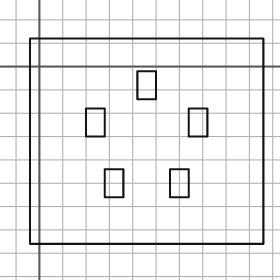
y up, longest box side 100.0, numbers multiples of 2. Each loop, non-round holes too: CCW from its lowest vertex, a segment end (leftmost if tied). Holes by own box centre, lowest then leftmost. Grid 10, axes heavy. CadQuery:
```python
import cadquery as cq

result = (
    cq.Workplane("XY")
    .moveTo(-4.0, -76.0)
    .lineTo(96.0, -76.0)
    .lineTo(96.0, 12.0)
    .lineTo(-4.0, 12.0)
    .close()
    .moveTo(28.0, -56.0)
    .lineTo(36.0, -56.0)
    .lineTo(36.0, -44.0)
    .lineTo(28.0, -44.0)
    .close()
    .moveTo(56.0, -56.0)
    .lineTo(64.0, -56.0)
    .lineTo(64.0, -44.0)
    .lineTo(56.0, -44.0)
    .close()
    .moveTo(20.0, -30.0)
    .lineTo(28.0, -30.0)
    .lineTo(28.0, -18.0)
    .lineTo(20.0, -18.0)
    .close()
    .moveTo(64.0, -30.0)
    .lineTo(72.0, -30.0)
    .lineTo(72.0, -18.0)
    .lineTo(64.0, -18.0)
    .close()
    .moveTo(42.0, -14.0)
    .lineTo(50.0, -14.0)
    .lineTo(50.0, -2.0)
    .lineTo(42.0, -2.0)
    .close()
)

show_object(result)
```